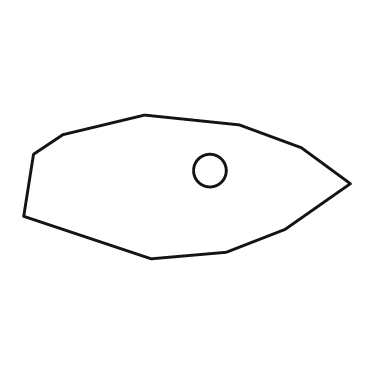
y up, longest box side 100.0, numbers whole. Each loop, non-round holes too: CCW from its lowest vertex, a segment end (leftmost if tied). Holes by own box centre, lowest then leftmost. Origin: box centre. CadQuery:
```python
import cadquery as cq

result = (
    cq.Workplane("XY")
    .moveTo(-11.0, -22.0)
    .lineTo(12.0, -20.0)
    .lineTo(30.0, -13.0)
    .lineTo(50.0, 1.0)
    .lineTo(35.0, 12.0)
    .lineTo(16.0, 19.0)
    .lineTo(-13.0, 22.0)
    .lineTo(-38.0, 16.0)
    .lineTo(-47.0, 10.0)
    .lineTo(-50.0, -9.0)
    .close()
    .moveTo(7.0, 5.0)
    .circle(5.0)
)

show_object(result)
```